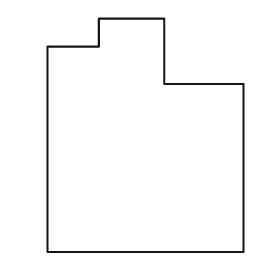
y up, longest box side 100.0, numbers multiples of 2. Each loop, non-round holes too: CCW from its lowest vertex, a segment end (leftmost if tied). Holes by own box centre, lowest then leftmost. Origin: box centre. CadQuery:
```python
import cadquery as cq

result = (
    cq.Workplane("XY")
    .moveTo(-42.0, -50.0)
    .lineTo(42.0, -50.0)
    .lineTo(42.0, 22.0)
    .lineTo(8.0, 22.0)
    .lineTo(8.0, 50.0)
    .lineTo(-20.0, 50.0)
    .lineTo(-20.0, 38.0)
    .lineTo(-42.0, 38.0)
    .close()
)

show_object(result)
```